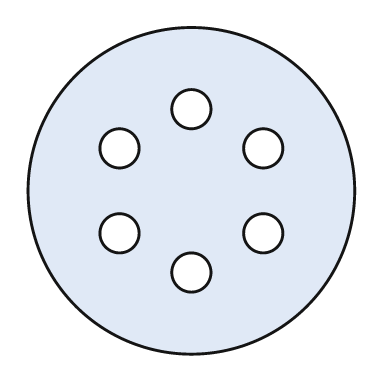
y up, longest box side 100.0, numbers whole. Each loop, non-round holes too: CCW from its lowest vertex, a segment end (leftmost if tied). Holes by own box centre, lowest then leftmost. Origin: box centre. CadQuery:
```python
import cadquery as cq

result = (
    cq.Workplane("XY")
    .moveTo(0.0, 0.0)
    .circle(50.0)
    .moveTo(0.0, -25.0)
    .circle(6.0)
    .moveTo(-22.0, -13.0)
    .circle(6.0)
    .moveTo(22.0, -13.0)
    .circle(6.0)
    .moveTo(-22.0, 13.0)
    .circle(6.0)
    .moveTo(22.0, 13.0)
    .circle(6.0)
    .moveTo(0.0, 25.0)
    .circle(6.0)
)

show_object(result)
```